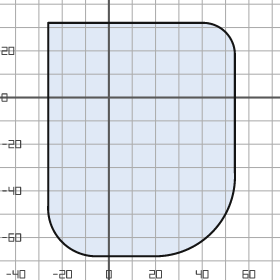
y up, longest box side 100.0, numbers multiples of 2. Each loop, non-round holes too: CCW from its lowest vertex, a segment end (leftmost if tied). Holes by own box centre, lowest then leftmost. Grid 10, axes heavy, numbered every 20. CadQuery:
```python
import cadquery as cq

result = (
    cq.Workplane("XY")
    .moveTo(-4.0, -68.0)
    .lineTo(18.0, -68.0)
    .threePointArc((44.0, -58.0), (54.0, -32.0))
    .lineTo(54.0, 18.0)
    .threePointArc((50.0, 28.0), (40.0, 32.0))
    .lineTo(-26.0, 32.0)
    .lineTo(-26.0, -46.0)
    .threePointArc((-20.0, -62.0), (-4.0, -68.0))
    .close()
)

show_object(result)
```